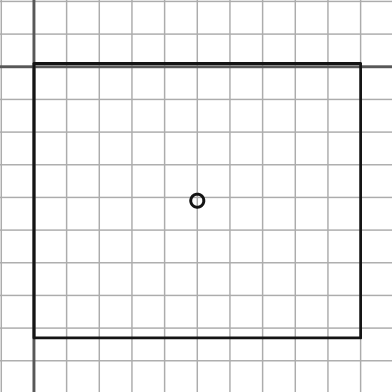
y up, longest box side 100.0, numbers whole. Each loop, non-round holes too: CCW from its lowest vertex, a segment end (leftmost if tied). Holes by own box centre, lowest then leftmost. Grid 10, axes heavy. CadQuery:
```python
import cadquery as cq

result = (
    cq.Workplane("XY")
    .moveTo(0.0, -83.0)
    .lineTo(100.0, -83.0)
    .lineTo(100.0, 1.0)
    .lineTo(0.0, 1.0)
    .close()
    .moveTo(50.0, -41.0)
    .circle(2.0)
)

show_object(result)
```